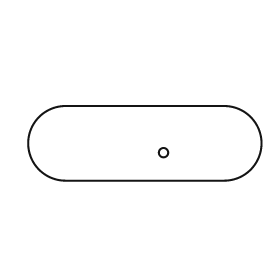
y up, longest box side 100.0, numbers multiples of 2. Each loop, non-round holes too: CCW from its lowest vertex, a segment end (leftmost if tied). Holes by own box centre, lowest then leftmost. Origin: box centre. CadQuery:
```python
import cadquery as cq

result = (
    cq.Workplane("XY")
    .moveTo(-34.0, -16.0)
    .lineTo(34.0, -16.0)
    .threePointArc((50.0, 0.0), (34.0, 16.0))
    .lineTo(-34.0, 16.0)
    .threePointArc((-50.0, 0.0), (-34.0, -16.0))
    .close()
    .moveTo(8.0, -4.0)
    .circle(2.0)
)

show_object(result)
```